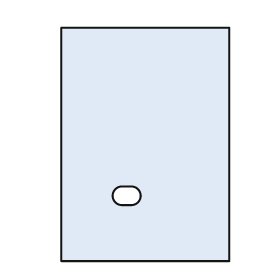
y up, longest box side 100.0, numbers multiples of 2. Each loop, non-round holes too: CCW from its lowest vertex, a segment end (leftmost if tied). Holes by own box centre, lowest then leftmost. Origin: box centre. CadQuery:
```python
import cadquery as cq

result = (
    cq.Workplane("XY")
    .moveTo(-36.0, -50.0)
    .lineTo(36.0, -50.0)
    .lineTo(36.0, 50.0)
    .lineTo(-36.0, 50.0)
    .close()
    .moveTo(-10.0, -26.0)
    .lineTo(-6.0, -26.0)
    .threePointArc((-2.0, -22.0), (-6.0, -18.0))
    .lineTo(-10.0, -18.0)
    .threePointArc((-14.0, -22.0), (-10.0, -26.0))
    .close()
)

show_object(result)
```